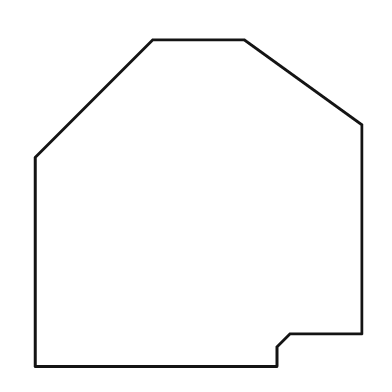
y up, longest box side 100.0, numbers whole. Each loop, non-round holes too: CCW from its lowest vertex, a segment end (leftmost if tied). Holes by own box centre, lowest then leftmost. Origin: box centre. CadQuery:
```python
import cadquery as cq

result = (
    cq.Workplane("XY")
    .moveTo(-50.0, -50.0)
    .lineTo(24.0, -50.0)
    .lineTo(24.0, -44.0)
    .lineTo(28.0, -40.0)
    .lineTo(50.0, -40.0)
    .lineTo(50.0, 24.0)
    .lineTo(14.0, 50.0)
    .lineTo(-14.0, 50.0)
    .lineTo(-50.0, 14.0)
    .close()
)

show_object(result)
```